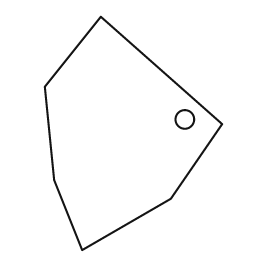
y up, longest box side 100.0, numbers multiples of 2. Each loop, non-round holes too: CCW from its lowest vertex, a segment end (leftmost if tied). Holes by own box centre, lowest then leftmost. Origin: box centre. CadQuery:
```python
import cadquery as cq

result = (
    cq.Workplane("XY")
    .moveTo(-22.0, -50.0)
    .lineTo(16.0, -28.0)
    .lineTo(38.0, 4.0)
    .lineTo(-14.0, 50.0)
    .lineTo(-38.0, 20.0)
    .lineTo(-34.0, -20.0)
    .close()
    .moveTo(22.0, 6.0)
    .circle(4.0)
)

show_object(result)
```